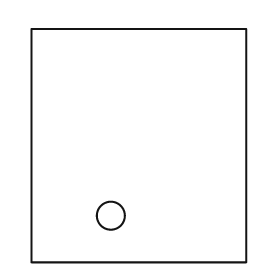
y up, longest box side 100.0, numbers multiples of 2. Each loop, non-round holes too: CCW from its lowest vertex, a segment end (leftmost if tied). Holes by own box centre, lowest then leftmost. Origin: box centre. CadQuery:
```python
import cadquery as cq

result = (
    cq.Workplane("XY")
    .moveTo(-46.0, -50.0)
    .lineTo(46.0, -50.0)
    .lineTo(46.0, 50.0)
    .lineTo(-46.0, 50.0)
    .close()
    .moveTo(-12.0, -30.0)
    .circle(6.0)
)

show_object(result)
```